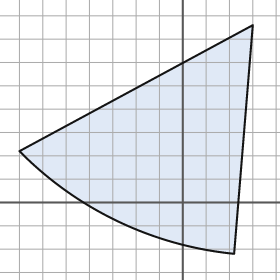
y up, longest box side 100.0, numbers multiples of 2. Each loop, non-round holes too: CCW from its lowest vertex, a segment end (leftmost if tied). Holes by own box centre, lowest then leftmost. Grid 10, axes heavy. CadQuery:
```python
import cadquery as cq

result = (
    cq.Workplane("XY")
    .moveTo(22.0, -22.0)
    .lineTo(30.0, 76.0)
    .lineTo(-70.0, 22.0)
    .threePointArc((-28.0, -8.0), (22.0, -22.0))
    .close()
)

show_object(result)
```